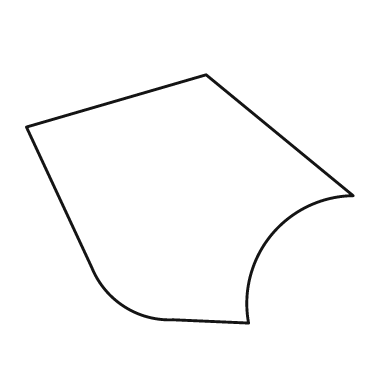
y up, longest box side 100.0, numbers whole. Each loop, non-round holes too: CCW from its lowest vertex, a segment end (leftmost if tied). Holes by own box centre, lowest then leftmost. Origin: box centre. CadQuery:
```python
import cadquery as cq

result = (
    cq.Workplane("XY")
    .moveTo(18.0, -38.0)
    .threePointArc((25.0, -11.0), (50.0, 1.0))
    .lineTo(5.0, 38.0)
    .lineTo(-50.0, 22.0)
    .lineTo(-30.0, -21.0)
    .threePointArc((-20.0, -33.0), (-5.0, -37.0))
    .close()
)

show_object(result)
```